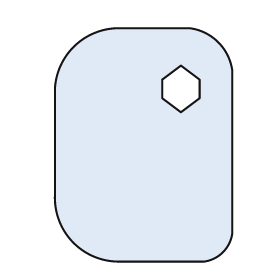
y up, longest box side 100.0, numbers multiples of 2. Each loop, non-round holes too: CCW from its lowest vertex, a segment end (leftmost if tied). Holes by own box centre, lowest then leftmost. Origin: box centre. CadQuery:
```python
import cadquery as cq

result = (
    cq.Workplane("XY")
    .moveTo(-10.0, -50.0)
    .lineTo(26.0, -50.0)
    .threePointArc((34.0, -46.0), (38.0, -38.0))
    .lineTo(38.0, 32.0)
    .threePointArc((32.0, 44.0), (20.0, 50.0))
    .lineTo(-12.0, 50.0)
    .threePointArc((-30.0, 42.0), (-38.0, 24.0))
    .lineTo(-38.0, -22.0)
    .threePointArc((-30.0, -42.0), (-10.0, -50.0))
    .close()
    .moveTo(16.0, 14.0)
    .lineTo(24.0, 20.0)
    .lineTo(24.0, 28.0)
    .lineTo(16.0, 34.0)
    .lineTo(8.0, 28.0)
    .lineTo(8.0, 20.0)
    .close()
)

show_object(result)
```